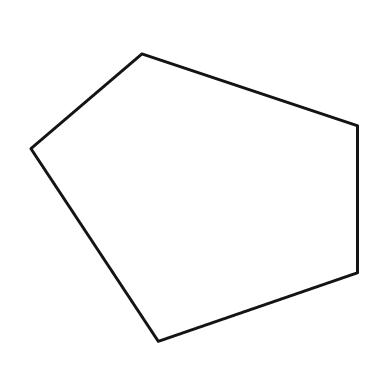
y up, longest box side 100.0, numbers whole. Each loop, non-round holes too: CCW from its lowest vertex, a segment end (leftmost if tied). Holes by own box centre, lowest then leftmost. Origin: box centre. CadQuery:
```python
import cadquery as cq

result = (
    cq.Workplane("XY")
    .moveTo(-11.0, -44.0)
    .lineTo(50.0, -23.0)
    .lineTo(50.0, 22.0)
    .lineTo(-16.0, 44.0)
    .lineTo(-50.0, 15.0)
    .close()
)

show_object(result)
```